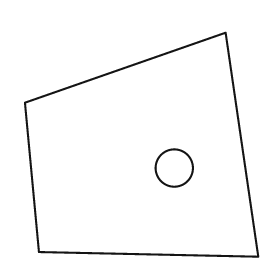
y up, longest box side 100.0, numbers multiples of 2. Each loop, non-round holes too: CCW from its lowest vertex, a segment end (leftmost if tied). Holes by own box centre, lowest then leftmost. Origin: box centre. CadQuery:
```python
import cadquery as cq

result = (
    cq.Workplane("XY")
    .moveTo(50.0, -48.0)
    .lineTo(36.0, 48.0)
    .lineTo(-50.0, 18.0)
    .lineTo(-44.0, -46.0)
    .close()
    .moveTo(14.0, -10.0)
    .circle(8.0)
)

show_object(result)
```